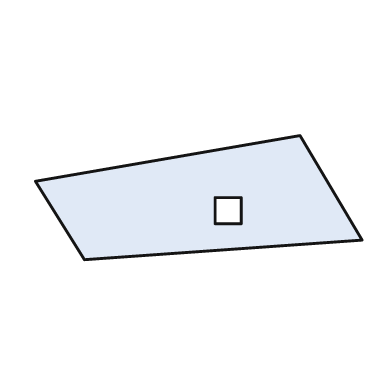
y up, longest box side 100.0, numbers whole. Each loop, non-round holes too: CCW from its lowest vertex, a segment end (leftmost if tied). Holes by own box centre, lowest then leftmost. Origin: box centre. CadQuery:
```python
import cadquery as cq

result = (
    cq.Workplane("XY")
    .moveTo(-35.0, -19.0)
    .lineTo(50.0, -13.0)
    .lineTo(31.0, 19.0)
    .lineTo(-50.0, 5.0)
    .close()
    .moveTo(5.0, -8.0)
    .lineTo(13.0, -8.0)
    .lineTo(13.0, 0.0)
    .lineTo(5.0, 0.0)
    .close()
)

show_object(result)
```